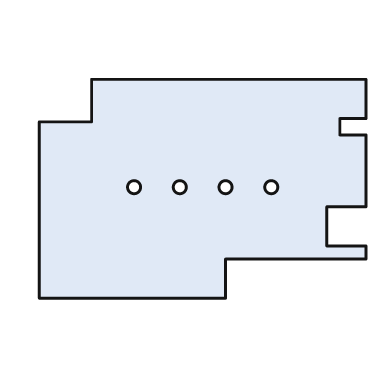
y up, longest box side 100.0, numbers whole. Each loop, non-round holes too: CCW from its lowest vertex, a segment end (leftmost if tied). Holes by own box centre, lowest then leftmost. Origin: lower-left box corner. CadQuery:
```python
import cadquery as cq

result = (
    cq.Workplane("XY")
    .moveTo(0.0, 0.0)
    .lineTo(57.0, 0.0)
    .lineTo(57.0, 12.0)
    .lineTo(100.0, 12.0)
    .lineTo(100.0, 16.0)
    .lineTo(88.0, 16.0)
    .lineTo(88.0, 28.0)
    .lineTo(100.0, 28.0)
    .lineTo(100.0, 50.0)
    .lineTo(92.0, 50.0)
    .lineTo(92.0, 55.0)
    .lineTo(100.0, 55.0)
    .lineTo(100.0, 67.0)
    .lineTo(16.0, 67.0)
    .lineTo(16.0, 54.0)
    .lineTo(0.0, 54.0)
    .close()
    .moveTo(29.0, 34.0)
    .circle(2.0)
    .moveTo(43.0, 34.0)
    .circle(2.0)
    .moveTo(57.0, 34.0)
    .circle(2.0)
    .moveTo(71.0, 34.0)
    .circle(2.0)
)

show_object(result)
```